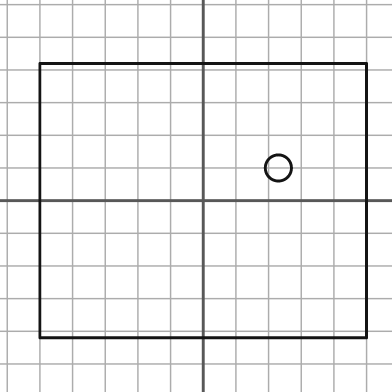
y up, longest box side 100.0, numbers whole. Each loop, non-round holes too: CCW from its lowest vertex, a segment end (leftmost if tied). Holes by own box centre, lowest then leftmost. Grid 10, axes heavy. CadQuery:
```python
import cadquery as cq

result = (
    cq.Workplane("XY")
    .moveTo(-50.0, -42.0)
    .lineTo(50.0, -42.0)
    .lineTo(50.0, 42.0)
    .lineTo(-50.0, 42.0)
    .close()
    .moveTo(23.0, 10.0)
    .circle(4.0)
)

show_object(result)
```